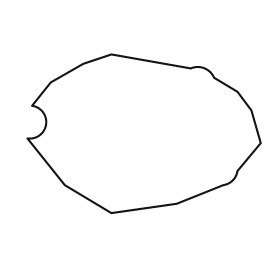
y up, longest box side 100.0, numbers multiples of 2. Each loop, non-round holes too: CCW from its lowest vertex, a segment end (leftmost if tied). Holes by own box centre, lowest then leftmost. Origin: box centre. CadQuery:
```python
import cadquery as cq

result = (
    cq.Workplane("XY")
    .moveTo(-14.0, -34.0)
    .lineTo(14.0, -30.0)
    .lineTo(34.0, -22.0)
    .threePointArc((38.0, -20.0), (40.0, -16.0))
    .lineTo(50.0, -4.0)
    .lineTo(46.0, 10.0)
    .lineTo(40.0, 18.0)
    .lineTo(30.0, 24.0)
    .threePointArc((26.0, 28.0), (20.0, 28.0))
    .lineTo(-14.0, 34.0)
    .lineTo(-26.0, 30.0)
    .lineTo(-40.0, 22.0)
    .lineTo(-48.0, 12.0)
    .threePointArc((-42.0, 4.0), (-50.0, -2.0))
    .lineTo(-34.0, -22.0)
    .close()
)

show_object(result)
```